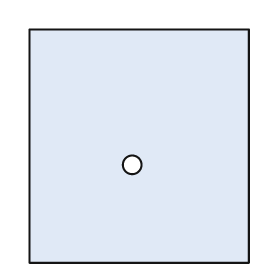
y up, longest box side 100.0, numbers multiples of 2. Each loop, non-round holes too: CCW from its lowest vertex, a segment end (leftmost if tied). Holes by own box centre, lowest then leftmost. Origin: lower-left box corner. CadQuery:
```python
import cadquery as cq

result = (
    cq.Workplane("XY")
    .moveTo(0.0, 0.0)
    .lineTo(94.0, 0.0)
    .lineTo(94.0, 100.0)
    .lineTo(0.0, 100.0)
    .close()
    .moveTo(44.0, 42.0)
    .circle(4.0)
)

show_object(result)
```